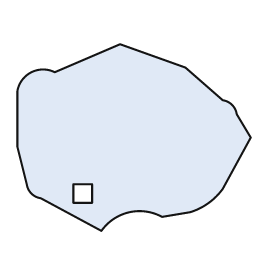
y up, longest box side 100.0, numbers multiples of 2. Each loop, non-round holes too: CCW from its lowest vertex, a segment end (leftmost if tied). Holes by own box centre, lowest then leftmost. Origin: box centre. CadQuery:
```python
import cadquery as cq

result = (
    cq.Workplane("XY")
    .moveTo(-14.0, -40.0)
    .threePointArc((-2.0, -32.0), (12.0, -34.0))
    .lineTo(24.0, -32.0)
    .threePointArc((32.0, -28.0), (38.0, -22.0))
    .lineTo(50.0, 0.0)
    .lineTo(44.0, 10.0)
    .threePointArc((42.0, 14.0), (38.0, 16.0))
    .lineTo(22.0, 30.0)
    .lineTo(-6.0, 40.0)
    .lineTo(-34.0, 28.0)
    .threePointArc((-44.0, 28.0), (-50.0, 20.0))
    .lineTo(-50.0, -4.0)
    .lineTo(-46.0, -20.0)
    .threePointArc((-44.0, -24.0), (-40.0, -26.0))
    .close()
    .moveTo(-26.0, -28.0)
    .lineTo(-18.0, -28.0)
    .lineTo(-18.0, -20.0)
    .lineTo(-26.0, -20.0)
    .close()
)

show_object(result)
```